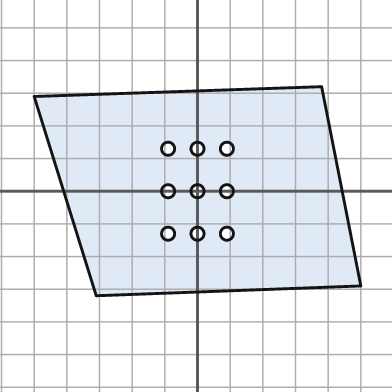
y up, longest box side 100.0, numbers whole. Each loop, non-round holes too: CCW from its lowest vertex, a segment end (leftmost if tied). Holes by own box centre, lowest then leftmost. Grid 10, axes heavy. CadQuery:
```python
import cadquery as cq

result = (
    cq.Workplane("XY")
    .moveTo(-31.0, -32.0)
    .lineTo(50.0, -29.0)
    .lineTo(38.0, 32.0)
    .lineTo(-50.0, 29.0)
    .close()
    .moveTo(-9.0, -13.0)
    .circle(2.0)
    .moveTo(0.0, -13.0)
    .circle(2.0)
    .moveTo(9.0, -13.0)
    .circle(2.0)
    .moveTo(-9.0, 0.0)
    .circle(2.0)
    .moveTo(0.0, 0.0)
    .circle(2.0)
    .moveTo(9.0, 0.0)
    .circle(2.0)
    .moveTo(-9.0, 13.0)
    .circle(2.0)
    .moveTo(0.0, 13.0)
    .circle(2.0)
    .moveTo(9.0, 13.0)
    .circle(2.0)
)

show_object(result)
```